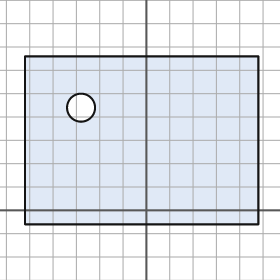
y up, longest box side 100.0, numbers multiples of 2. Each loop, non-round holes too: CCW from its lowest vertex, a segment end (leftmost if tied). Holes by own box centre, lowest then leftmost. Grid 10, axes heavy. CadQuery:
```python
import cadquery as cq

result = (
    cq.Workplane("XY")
    .moveTo(-52.0, -6.0)
    .lineTo(48.0, -6.0)
    .lineTo(48.0, 66.0)
    .lineTo(-52.0, 66.0)
    .close()
    .moveTo(-28.0, 44.0)
    .circle(6.0)
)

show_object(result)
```